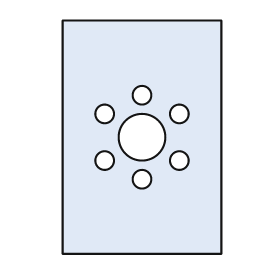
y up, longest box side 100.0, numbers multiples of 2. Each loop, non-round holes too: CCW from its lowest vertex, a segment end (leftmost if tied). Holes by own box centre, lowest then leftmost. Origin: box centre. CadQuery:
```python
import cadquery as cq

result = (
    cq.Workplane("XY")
    .moveTo(-34.0, -50.0)
    .lineTo(34.0, -50.0)
    .lineTo(34.0, 50.0)
    .lineTo(-34.0, 50.0)
    .close()
    .moveTo(0.0, -18.0)
    .circle(4.0)
    .moveTo(-16.0, -10.0)
    .circle(4.0)
    .moveTo(16.0, -10.0)
    .circle(4.0)
    .moveTo(0.0, 0.0)
    .circle(10.0)
    .moveTo(-16.0, 10.0)
    .circle(4.0)
    .moveTo(16.0, 10.0)
    .circle(4.0)
    .moveTo(0.0, 18.0)
    .circle(4.0)
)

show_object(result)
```